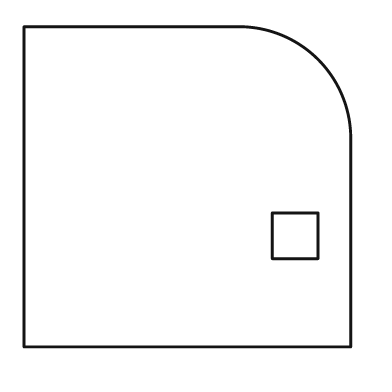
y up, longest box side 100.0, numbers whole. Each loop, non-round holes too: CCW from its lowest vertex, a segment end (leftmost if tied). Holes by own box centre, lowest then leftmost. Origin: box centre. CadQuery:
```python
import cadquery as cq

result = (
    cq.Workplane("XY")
    .moveTo(-50.0, -49.0)
    .lineTo(50.0, -49.0)
    .lineTo(50.0, 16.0)
    .threePointArc((40.0, 39.0), (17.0, 49.0))
    .lineTo(-50.0, 49.0)
    .close()
    .moveTo(26.0, -22.0)
    .lineTo(40.0, -22.0)
    .lineTo(40.0, -8.0)
    .lineTo(26.0, -8.0)
    .close()
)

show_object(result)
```